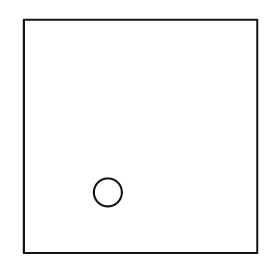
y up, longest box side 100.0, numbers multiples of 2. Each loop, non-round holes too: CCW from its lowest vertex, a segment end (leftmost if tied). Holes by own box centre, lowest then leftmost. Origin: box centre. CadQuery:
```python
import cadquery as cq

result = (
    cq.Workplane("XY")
    .moveTo(-50.0, -50.0)
    .lineTo(50.0, -50.0)
    .lineTo(50.0, 50.0)
    .lineTo(-50.0, 50.0)
    .close()
    .moveTo(-14.0, -24.0)
    .circle(6.0)
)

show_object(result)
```